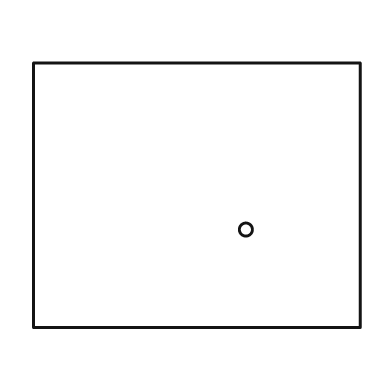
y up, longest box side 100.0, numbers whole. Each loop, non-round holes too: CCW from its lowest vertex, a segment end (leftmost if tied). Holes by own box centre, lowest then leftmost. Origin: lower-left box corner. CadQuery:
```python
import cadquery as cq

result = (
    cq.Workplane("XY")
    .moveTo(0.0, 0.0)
    .lineTo(100.0, 0.0)
    .lineTo(100.0, 81.0)
    .lineTo(0.0, 81.0)
    .close()
    .moveTo(65.0, 30.0)
    .circle(2.0)
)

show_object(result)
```